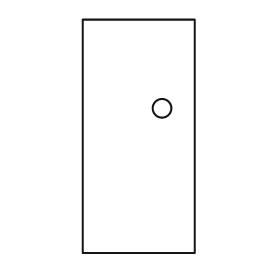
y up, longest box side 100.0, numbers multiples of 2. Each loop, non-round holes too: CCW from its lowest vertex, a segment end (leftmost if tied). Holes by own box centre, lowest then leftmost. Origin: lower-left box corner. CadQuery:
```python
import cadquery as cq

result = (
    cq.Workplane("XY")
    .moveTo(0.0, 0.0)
    .lineTo(48.0, 0.0)
    .lineTo(48.0, 100.0)
    .lineTo(0.0, 100.0)
    .close()
    .moveTo(34.0, 62.0)
    .circle(4.0)
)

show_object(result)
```